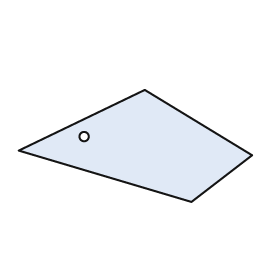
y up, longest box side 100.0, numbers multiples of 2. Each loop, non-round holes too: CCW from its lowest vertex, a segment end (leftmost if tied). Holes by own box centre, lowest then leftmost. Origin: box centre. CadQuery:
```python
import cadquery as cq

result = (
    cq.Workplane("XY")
    .moveTo(24.0, -24.0)
    .lineTo(50.0, -4.0)
    .lineTo(4.0, 24.0)
    .lineTo(-50.0, -2.0)
    .close()
    .moveTo(-22.0, 4.0)
    .circle(2.0)
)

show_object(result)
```